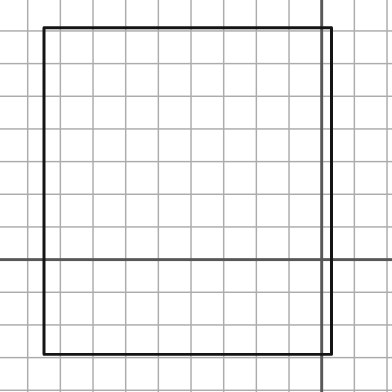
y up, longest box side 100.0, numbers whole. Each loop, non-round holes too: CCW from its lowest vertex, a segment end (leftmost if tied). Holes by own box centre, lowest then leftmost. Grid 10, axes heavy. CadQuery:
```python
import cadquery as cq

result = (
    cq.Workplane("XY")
    .moveTo(-85.0, -29.0)
    .lineTo(3.0, -29.0)
    .lineTo(3.0, 71.0)
    .lineTo(-85.0, 71.0)
    .close()
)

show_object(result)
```